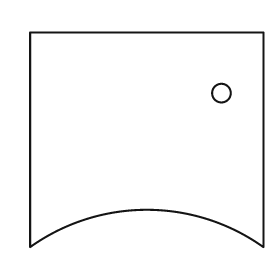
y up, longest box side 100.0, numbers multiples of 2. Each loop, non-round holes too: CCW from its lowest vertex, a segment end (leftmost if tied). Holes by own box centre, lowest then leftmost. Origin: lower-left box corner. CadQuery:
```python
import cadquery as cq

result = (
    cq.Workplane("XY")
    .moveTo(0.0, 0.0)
    .threePointArc((50.0, 16.0), (100.0, 0.0))
    .lineTo(100.0, 92.0)
    .lineTo(0.0, 92.0)
    .close()
    .moveTo(82.0, 66.0)
    .circle(4.0)
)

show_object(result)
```